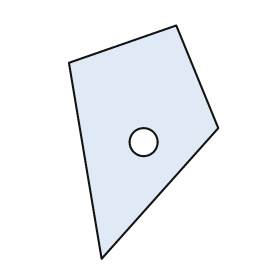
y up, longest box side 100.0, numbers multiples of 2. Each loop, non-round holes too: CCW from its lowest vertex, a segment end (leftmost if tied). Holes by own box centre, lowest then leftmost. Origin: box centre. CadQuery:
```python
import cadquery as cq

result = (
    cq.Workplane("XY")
    .moveTo(-18.0, -50.0)
    .lineTo(32.0, 6.0)
    .lineTo(14.0, 50.0)
    .lineTo(-32.0, 34.0)
    .close()
    .moveTo(0.0, 0.0)
    .circle(6.0)
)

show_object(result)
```